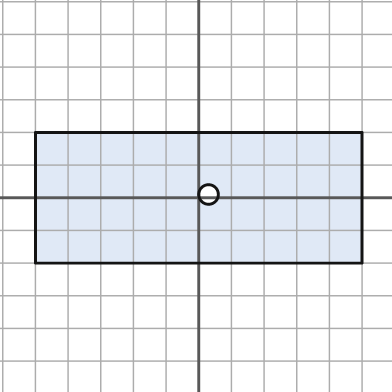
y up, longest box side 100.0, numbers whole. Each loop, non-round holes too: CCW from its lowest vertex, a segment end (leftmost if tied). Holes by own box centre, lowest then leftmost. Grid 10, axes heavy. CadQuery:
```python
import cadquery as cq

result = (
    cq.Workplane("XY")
    .moveTo(-50.0, -20.0)
    .lineTo(50.0, -20.0)
    .lineTo(50.0, 20.0)
    .lineTo(-50.0, 20.0)
    .close()
    .moveTo(3.0, 1.0)
    .circle(3.0)
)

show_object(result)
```